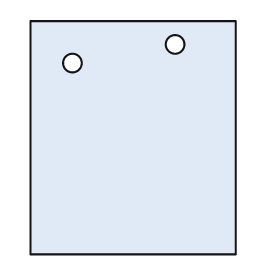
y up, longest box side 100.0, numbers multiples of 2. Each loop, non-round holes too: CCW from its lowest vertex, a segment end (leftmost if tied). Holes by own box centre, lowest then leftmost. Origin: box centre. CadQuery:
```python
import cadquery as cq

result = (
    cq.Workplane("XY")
    .moveTo(-44.0, -50.0)
    .lineTo(44.0, -50.0)
    .lineTo(44.0, 50.0)
    .lineTo(-44.0, 50.0)
    .close()
    .moveTo(-26.0, 32.0)
    .circle(4.0)
    .moveTo(18.0, 40.0)
    .circle(4.0)
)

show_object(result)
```